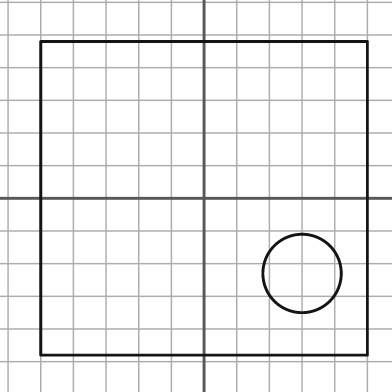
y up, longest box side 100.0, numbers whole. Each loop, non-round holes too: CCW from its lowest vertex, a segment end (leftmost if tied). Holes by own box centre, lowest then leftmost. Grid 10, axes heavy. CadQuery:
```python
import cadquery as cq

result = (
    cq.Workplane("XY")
    .moveTo(-50.0, -48.0)
    .lineTo(50.0, -48.0)
    .lineTo(50.0, 48.0)
    .lineTo(-50.0, 48.0)
    .close()
    .moveTo(30.0, -23.0)
    .circle(12.0)
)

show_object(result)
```